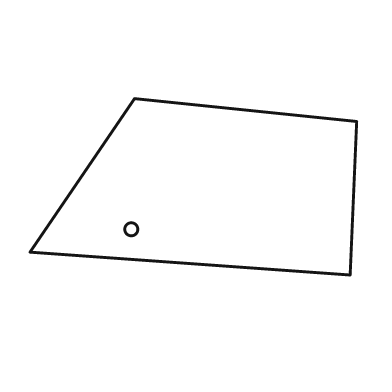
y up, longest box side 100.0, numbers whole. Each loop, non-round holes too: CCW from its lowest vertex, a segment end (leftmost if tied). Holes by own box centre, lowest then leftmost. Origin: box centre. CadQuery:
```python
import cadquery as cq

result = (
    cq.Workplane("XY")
    .moveTo(48.0, -27.0)
    .lineTo(50.0, 20.0)
    .lineTo(-18.0, 27.0)
    .lineTo(-50.0, -20.0)
    .close()
    .moveTo(-19.0, -13.0)
    .circle(2.0)
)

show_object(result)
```